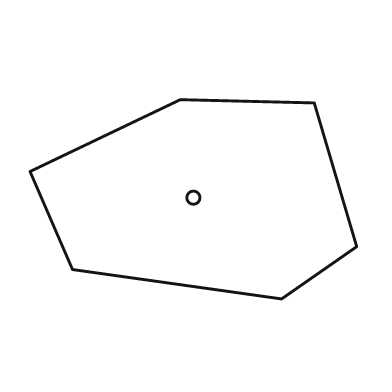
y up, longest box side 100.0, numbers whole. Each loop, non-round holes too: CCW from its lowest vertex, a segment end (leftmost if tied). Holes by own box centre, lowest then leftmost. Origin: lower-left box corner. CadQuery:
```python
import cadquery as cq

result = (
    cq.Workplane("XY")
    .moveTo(77.0, 0.0)
    .lineTo(100.0, 16.0)
    .lineTo(87.0, 60.0)
    .lineTo(46.0, 61.0)
    .lineTo(0.0, 39.0)
    .lineTo(13.0, 9.0)
    .close()
    .moveTo(50.0, 31.0)
    .circle(2.0)
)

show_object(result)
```